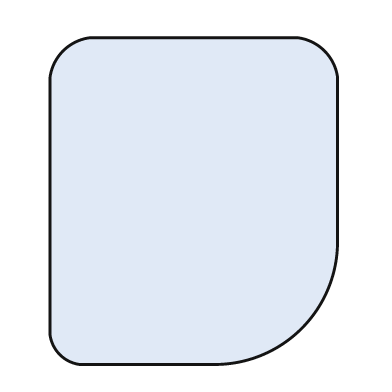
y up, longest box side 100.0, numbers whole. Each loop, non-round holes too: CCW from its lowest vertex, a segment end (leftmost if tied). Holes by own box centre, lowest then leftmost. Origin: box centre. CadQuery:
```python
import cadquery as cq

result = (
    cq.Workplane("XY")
    .moveTo(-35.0, -50.0)
    .lineTo(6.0, -50.0)
    .threePointArc((33.0, -39.0), (44.0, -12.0))
    .lineTo(44.0, 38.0)
    .threePointArc((40.0, 46.0), (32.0, 50.0))
    .lineTo(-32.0, 50.0)
    .threePointArc((-40.0, 46.0), (-44.0, 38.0))
    .lineTo(-44.0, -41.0)
    .threePointArc((-41.0, -47.0), (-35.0, -50.0))
    .close()
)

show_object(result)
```